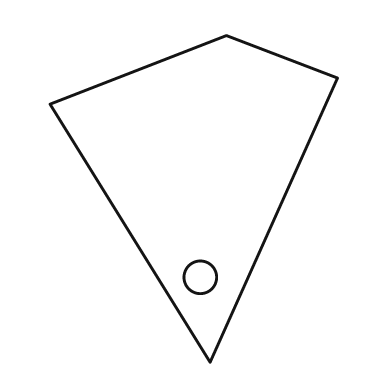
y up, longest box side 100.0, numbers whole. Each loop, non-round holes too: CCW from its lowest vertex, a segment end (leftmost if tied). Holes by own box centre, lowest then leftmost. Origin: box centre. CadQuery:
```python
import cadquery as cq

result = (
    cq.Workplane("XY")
    .moveTo(5.0, -50.0)
    .lineTo(44.0, 37.0)
    .lineTo(10.0, 50.0)
    .lineTo(-44.0, 29.0)
    .close()
    .moveTo(2.0, -24.0)
    .circle(5.0)
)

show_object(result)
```